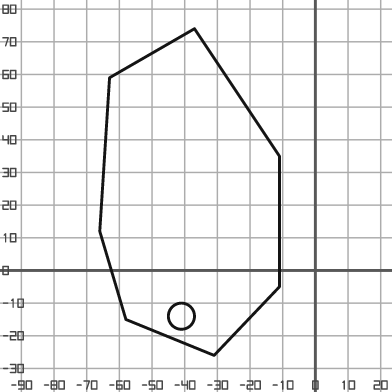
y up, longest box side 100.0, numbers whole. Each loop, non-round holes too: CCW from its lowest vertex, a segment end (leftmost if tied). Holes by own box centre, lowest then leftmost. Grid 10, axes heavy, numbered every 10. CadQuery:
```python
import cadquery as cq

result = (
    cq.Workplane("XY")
    .moveTo(-31.0, -26.0)
    .lineTo(-11.0, -5.0)
    .lineTo(-11.0, 35.0)
    .lineTo(-37.0, 74.0)
    .lineTo(-63.0, 59.0)
    .lineTo(-66.0, 12.0)
    .lineTo(-58.0, -15.0)
    .close()
    .moveTo(-41.0, -14.0)
    .circle(4.0)
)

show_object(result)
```